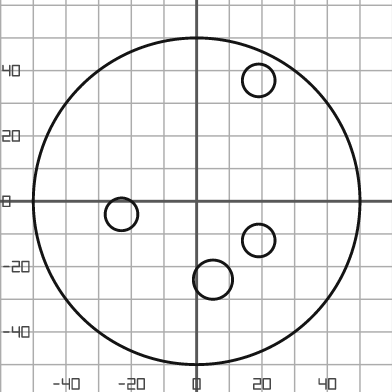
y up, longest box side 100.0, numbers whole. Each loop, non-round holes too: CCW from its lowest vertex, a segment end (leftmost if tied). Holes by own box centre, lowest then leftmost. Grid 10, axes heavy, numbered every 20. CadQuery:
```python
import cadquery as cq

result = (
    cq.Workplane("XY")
    .moveTo(0.0, 0.0)
    .circle(50.0)
    .moveTo(5.0, -24.0)
    .circle(6.0)
    .moveTo(19.0, -12.0)
    .circle(5.0)
    .moveTo(-23.0, -4.0)
    .circle(5.0)
    .moveTo(19.0, 37.0)
    .circle(5.0)
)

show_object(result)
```